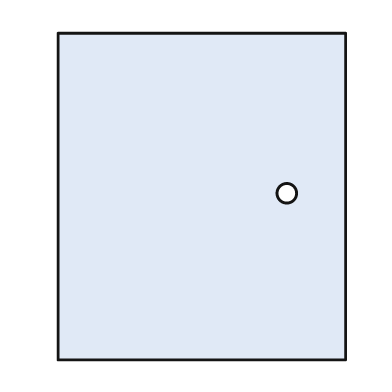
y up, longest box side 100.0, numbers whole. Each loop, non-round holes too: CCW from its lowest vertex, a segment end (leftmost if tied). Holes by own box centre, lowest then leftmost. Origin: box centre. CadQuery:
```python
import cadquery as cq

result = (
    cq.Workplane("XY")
    .moveTo(-44.0, -50.0)
    .lineTo(44.0, -50.0)
    .lineTo(44.0, 50.0)
    .lineTo(-44.0, 50.0)
    .close()
    .moveTo(26.0, 1.0)
    .circle(3.0)
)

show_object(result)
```